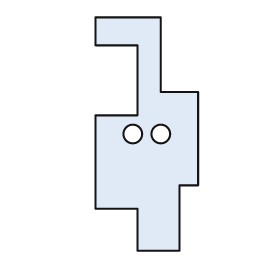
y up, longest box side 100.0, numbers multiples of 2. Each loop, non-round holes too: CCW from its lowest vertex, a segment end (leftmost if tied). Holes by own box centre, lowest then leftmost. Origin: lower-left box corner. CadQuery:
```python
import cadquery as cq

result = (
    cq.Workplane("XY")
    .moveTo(18.0, 0.0)
    .lineTo(36.0, 0.0)
    .lineTo(36.0, 28.0)
    .lineTo(44.0, 28.0)
    .lineTo(44.0, 68.0)
    .lineTo(28.0, 68.0)
    .lineTo(28.0, 100.0)
    .lineTo(0.0, 100.0)
    .lineTo(0.0, 88.0)
    .lineTo(18.0, 88.0)
    .lineTo(18.0, 58.0)
    .lineTo(0.0, 58.0)
    .lineTo(0.0, 18.0)
    .lineTo(18.0, 18.0)
    .close()
    .moveTo(16.0, 50.0)
    .circle(4.0)
    .moveTo(28.0, 50.0)
    .circle(4.0)
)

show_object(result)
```